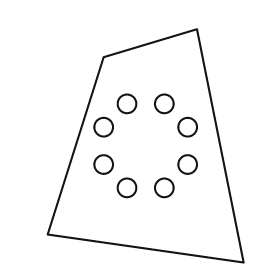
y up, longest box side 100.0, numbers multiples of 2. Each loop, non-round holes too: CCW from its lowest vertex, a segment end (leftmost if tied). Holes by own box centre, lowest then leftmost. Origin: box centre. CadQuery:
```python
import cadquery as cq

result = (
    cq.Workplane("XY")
    .moveTo(42.0, -50.0)
    .lineTo(22.0, 50.0)
    .lineTo(-18.0, 38.0)
    .lineTo(-42.0, -38.0)
    .close()
    .moveTo(-8.0, -18.0)
    .circle(4.0)
    .moveTo(8.0, -18.0)
    .circle(4.0)
    .moveTo(-18.0, -8.0)
    .circle(4.0)
    .moveTo(18.0, -8.0)
    .circle(4.0)
    .moveTo(-18.0, 8.0)
    .circle(4.0)
    .moveTo(18.0, 8.0)
    .circle(4.0)
    .moveTo(-8.0, 18.0)
    .circle(4.0)
    .moveTo(8.0, 18.0)
    .circle(4.0)
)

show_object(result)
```